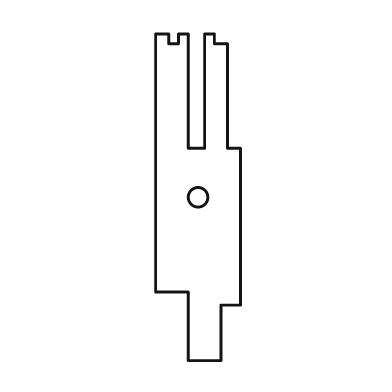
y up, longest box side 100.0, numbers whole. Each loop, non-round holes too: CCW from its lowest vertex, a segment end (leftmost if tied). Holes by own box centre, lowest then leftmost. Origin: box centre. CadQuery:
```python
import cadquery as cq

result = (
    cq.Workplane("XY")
    .moveTo(-3.0, -50.0)
    .lineTo(7.0, -50.0)
    .lineTo(7.0, -33.0)
    .lineTo(13.0, -33.0)
    .lineTo(13.0, 15.0)
    .lineTo(9.0, 15.0)
    .lineTo(9.0, 47.0)
    .lineTo(5.0, 47.0)
    .lineTo(5.0, 50.0)
    .lineTo(2.0, 50.0)
    .lineTo(2.0, 15.0)
    .lineTo(-3.0, 15.0)
    .lineTo(-3.0, 50.0)
    .lineTo(-6.0, 50.0)
    .lineTo(-6.0, 47.0)
    .lineTo(-9.0, 47.0)
    .lineTo(-9.0, 50.0)
    .lineTo(-13.0, 50.0)
    .lineTo(-13.0, -29.0)
    .lineTo(-3.0, -29.0)
    .close()
    .moveTo(0.0, 0.0)
    .circle(3.0)
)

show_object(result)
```